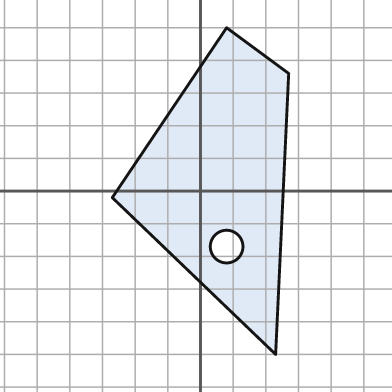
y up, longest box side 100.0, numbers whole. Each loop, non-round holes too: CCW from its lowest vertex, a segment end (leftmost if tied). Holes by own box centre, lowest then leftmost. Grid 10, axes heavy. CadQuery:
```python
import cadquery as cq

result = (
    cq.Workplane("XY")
    .moveTo(23.0, -50.0)
    .lineTo(27.0, 36.0)
    .lineTo(8.0, 50.0)
    .lineTo(-27.0, -2.0)
    .close()
    .moveTo(8.0, -17.0)
    .circle(5.0)
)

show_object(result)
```